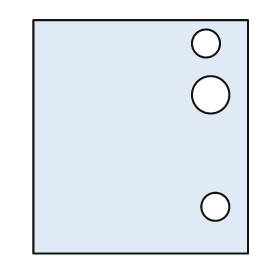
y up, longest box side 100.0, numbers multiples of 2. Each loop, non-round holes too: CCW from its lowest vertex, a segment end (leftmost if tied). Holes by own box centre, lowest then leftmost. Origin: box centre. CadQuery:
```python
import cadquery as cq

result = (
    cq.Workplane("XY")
    .moveTo(-46.0, -50.0)
    .lineTo(46.0, -50.0)
    .lineTo(46.0, 50.0)
    .lineTo(-46.0, 50.0)
    .close()
    .moveTo(32.0, -30.0)
    .circle(6.0)
    .moveTo(30.0, 18.0)
    .circle(8.0)
    .moveTo(28.0, 40.0)
    .circle(6.0)
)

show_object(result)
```